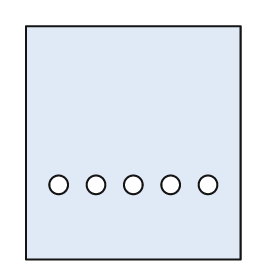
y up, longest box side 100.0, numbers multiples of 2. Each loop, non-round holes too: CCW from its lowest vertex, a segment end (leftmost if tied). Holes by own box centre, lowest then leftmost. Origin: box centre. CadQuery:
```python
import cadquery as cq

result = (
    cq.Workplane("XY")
    .moveTo(-46.0, -50.0)
    .lineTo(46.0, -50.0)
    .lineTo(46.0, 50.0)
    .lineTo(-46.0, 50.0)
    .close()
    .moveTo(-32.0, -18.0)
    .circle(4.0)
    .moveTo(-16.0, -18.0)
    .circle(4.0)
    .moveTo(0.0, -18.0)
    .circle(4.0)
    .moveTo(16.0, -18.0)
    .circle(4.0)
    .moveTo(32.0, -18.0)
    .circle(4.0)
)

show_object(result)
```